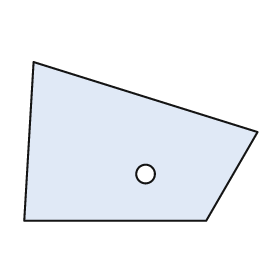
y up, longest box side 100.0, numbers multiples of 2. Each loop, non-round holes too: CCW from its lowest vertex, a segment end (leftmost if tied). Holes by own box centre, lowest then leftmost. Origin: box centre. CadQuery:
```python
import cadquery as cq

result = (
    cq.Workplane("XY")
    .moveTo(-50.0, -34.0)
    .lineTo(28.0, -34.0)
    .lineTo(50.0, 4.0)
    .lineTo(-46.0, 34.0)
    .close()
    .moveTo(2.0, -14.0)
    .circle(4.0)
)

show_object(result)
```